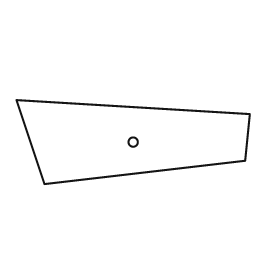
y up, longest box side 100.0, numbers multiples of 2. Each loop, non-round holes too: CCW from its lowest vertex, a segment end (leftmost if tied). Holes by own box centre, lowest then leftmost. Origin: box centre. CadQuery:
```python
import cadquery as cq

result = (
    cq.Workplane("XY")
    .moveTo(-38.0, -18.0)
    .lineTo(48.0, -8.0)
    .lineTo(50.0, 12.0)
    .lineTo(-50.0, 18.0)
    .close()
    .moveTo(0.0, 0.0)
    .circle(2.0)
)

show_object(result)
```